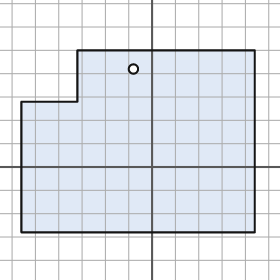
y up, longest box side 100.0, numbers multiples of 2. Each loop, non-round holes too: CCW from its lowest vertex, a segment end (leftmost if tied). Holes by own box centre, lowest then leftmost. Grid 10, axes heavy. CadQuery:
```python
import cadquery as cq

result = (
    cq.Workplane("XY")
    .moveTo(-56.0, -28.0)
    .lineTo(44.0, -28.0)
    .lineTo(44.0, 50.0)
    .lineTo(-32.0, 50.0)
    .lineTo(-32.0, 28.0)
    .lineTo(-56.0, 28.0)
    .close()
    .moveTo(-8.0, 42.0)
    .circle(2.0)
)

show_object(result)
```